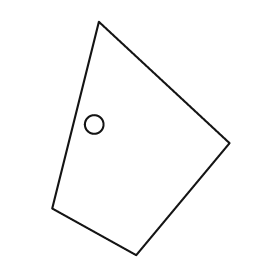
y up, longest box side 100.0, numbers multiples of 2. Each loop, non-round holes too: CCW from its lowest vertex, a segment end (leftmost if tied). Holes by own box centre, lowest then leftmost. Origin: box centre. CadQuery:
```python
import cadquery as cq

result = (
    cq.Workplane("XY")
    .moveTo(-2.0, -50.0)
    .lineTo(38.0, -2.0)
    .lineTo(-18.0, 50.0)
    .lineTo(-38.0, -30.0)
    .close()
    .moveTo(-20.0, 6.0)
    .circle(4.0)
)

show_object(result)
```